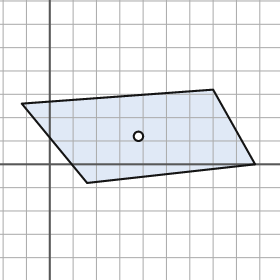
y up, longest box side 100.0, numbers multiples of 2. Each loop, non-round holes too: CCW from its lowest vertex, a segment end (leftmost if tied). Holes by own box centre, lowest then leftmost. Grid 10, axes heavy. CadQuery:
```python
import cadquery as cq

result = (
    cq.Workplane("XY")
    .moveTo(16.0, -8.0)
    .lineTo(88.0, 0.0)
    .lineTo(70.0, 32.0)
    .lineTo(-12.0, 26.0)
    .close()
    .moveTo(38.0, 12.0)
    .circle(2.0)
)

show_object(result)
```